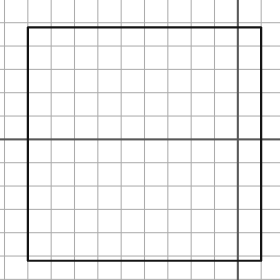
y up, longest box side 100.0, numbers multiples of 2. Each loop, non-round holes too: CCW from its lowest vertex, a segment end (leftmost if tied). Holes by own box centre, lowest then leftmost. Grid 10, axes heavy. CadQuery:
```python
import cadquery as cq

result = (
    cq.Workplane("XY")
    .moveTo(-90.0, -52.0)
    .lineTo(10.0, -52.0)
    .lineTo(10.0, 48.0)
    .lineTo(-90.0, 48.0)
    .close()
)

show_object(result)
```